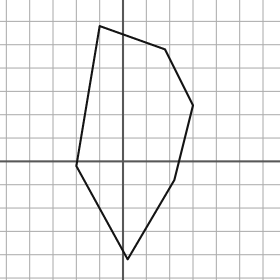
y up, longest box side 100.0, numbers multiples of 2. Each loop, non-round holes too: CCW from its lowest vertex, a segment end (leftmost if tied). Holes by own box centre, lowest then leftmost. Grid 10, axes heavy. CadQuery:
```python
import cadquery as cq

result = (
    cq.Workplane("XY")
    .moveTo(2.0, -42.0)
    .lineTo(22.0, -8.0)
    .lineTo(30.0, 24.0)
    .lineTo(18.0, 48.0)
    .lineTo(-10.0, 58.0)
    .lineTo(-20.0, -2.0)
    .close()
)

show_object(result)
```